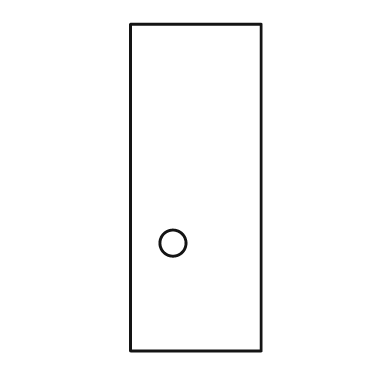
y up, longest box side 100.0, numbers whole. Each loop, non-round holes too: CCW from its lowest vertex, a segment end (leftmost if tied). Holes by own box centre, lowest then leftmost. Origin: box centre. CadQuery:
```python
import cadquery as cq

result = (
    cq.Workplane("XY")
    .moveTo(-20.0, -50.0)
    .lineTo(20.0, -50.0)
    .lineTo(20.0, 50.0)
    .lineTo(-20.0, 50.0)
    .close()
    .moveTo(-7.0, -17.0)
    .circle(4.0)
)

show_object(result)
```